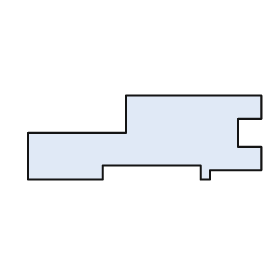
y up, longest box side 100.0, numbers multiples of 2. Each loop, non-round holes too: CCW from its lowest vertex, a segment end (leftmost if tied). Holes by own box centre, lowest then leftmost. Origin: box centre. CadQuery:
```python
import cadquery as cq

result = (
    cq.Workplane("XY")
    .moveTo(-50.0, -18.0)
    .lineTo(-18.0, -18.0)
    .lineTo(-18.0, -12.0)
    .lineTo(24.0, -12.0)
    .lineTo(24.0, -18.0)
    .lineTo(28.0, -18.0)
    .lineTo(28.0, -14.0)
    .lineTo(50.0, -14.0)
    .lineTo(50.0, -4.0)
    .lineTo(40.0, -4.0)
    .lineTo(40.0, 8.0)
    .lineTo(50.0, 8.0)
    .lineTo(50.0, 18.0)
    .lineTo(-8.0, 18.0)
    .lineTo(-8.0, 2.0)
    .lineTo(-50.0, 2.0)
    .close()
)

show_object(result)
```